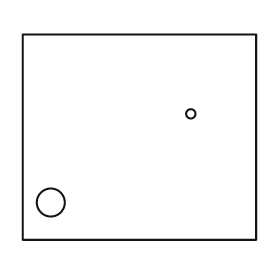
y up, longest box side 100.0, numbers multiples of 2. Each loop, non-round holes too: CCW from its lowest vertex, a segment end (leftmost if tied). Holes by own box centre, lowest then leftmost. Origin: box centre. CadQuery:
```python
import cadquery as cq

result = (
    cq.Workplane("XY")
    .moveTo(-50.0, -44.0)
    .lineTo(50.0, -44.0)
    .lineTo(50.0, 44.0)
    .lineTo(-50.0, 44.0)
    .close()
    .moveTo(-38.0, -28.0)
    .circle(6.0)
    .moveTo(22.0, 10.0)
    .circle(2.0)
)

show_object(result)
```